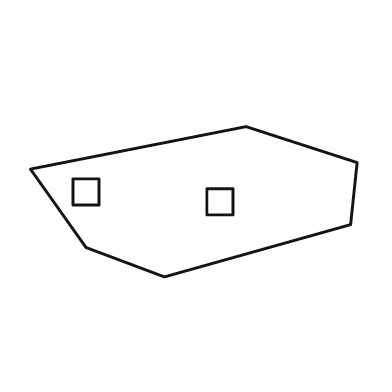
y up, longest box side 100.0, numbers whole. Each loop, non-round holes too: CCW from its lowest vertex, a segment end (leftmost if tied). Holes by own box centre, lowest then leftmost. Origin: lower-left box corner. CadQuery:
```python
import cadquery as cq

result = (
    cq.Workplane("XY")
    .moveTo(41.0, 0.0)
    .lineTo(98.0, 16.0)
    .lineTo(100.0, 35.0)
    .lineTo(66.0, 46.0)
    .lineTo(0.0, 33.0)
    .lineTo(17.0, 9.0)
    .close()
    .moveTo(54.0, 19.0)
    .lineTo(62.0, 19.0)
    .lineTo(62.0, 27.0)
    .lineTo(54.0, 27.0)
    .close()
    .moveTo(13.0, 22.0)
    .lineTo(21.0, 22.0)
    .lineTo(21.0, 30.0)
    .lineTo(13.0, 30.0)
    .close()
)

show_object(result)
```